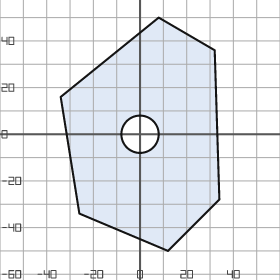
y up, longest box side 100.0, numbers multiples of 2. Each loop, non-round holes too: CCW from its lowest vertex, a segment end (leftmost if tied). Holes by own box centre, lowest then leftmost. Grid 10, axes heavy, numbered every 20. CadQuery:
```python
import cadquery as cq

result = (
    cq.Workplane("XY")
    .moveTo(12.0, -50.0)
    .lineTo(34.0, -28.0)
    .lineTo(32.0, 36.0)
    .lineTo(8.0, 50.0)
    .lineTo(-34.0, 16.0)
    .lineTo(-26.0, -34.0)
    .close()
    .moveTo(0.0, 0.0)
    .circle(8.0)
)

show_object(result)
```